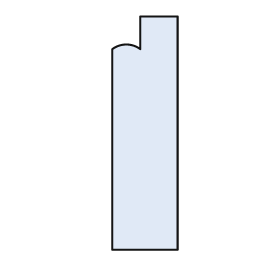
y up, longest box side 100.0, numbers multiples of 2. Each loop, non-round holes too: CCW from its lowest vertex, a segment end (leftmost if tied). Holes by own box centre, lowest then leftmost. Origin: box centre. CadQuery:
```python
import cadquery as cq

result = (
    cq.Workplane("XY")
    .moveTo(-14.0, -50.0)
    .lineTo(14.0, -50.0)
    .lineTo(14.0, 50.0)
    .lineTo(-2.0, 50.0)
    .lineTo(-2.0, 36.0)
    .threePointArc((-8.0, 38.0), (-14.0, 36.0))
    .close()
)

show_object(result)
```